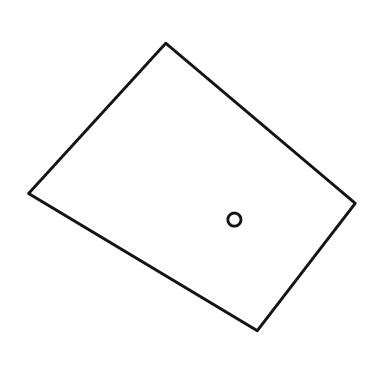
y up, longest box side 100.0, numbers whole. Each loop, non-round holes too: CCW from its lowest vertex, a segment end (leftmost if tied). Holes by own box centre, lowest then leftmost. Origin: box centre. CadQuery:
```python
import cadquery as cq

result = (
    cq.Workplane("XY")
    .moveTo(20.0, -44.0)
    .lineTo(50.0, -5.0)
    .lineTo(-8.0, 44.0)
    .lineTo(-50.0, -2.0)
    .close()
    .moveTo(13.0, -10.0)
    .circle(2.0)
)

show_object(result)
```